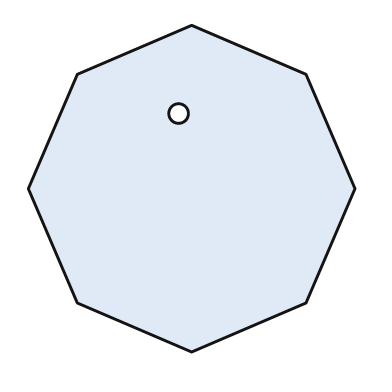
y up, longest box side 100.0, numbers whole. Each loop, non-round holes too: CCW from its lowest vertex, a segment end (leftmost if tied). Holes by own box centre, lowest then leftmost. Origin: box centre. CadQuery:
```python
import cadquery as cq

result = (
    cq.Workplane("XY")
    .moveTo(0.0, -50.0)
    .lineTo(35.0, -35.0)
    .lineTo(50.0, 0.0)
    .lineTo(35.0, 35.0)
    .lineTo(0.0, 50.0)
    .lineTo(-35.0, 35.0)
    .lineTo(-50.0, 0.0)
    .lineTo(-35.0, -35.0)
    .close()
    .moveTo(-4.0, 23.0)
    .circle(3.0)
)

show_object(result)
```